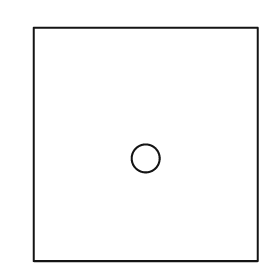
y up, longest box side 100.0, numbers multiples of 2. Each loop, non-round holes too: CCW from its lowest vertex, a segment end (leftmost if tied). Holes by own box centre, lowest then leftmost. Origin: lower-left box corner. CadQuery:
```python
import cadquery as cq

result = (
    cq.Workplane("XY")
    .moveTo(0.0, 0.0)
    .lineTo(96.0, 0.0)
    .lineTo(96.0, 100.0)
    .lineTo(0.0, 100.0)
    .close()
    .moveTo(48.0, 44.0)
    .circle(6.0)
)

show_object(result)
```